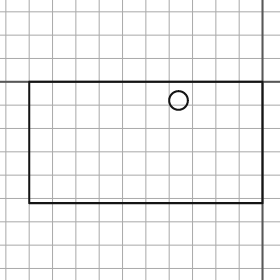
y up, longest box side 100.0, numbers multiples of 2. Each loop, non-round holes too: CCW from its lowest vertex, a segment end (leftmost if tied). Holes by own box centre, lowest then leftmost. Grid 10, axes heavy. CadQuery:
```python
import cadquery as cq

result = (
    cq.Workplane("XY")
    .moveTo(-100.0, -52.0)
    .lineTo(0.0, -52.0)
    .lineTo(0.0, 0.0)
    .lineTo(-100.0, 0.0)
    .close()
    .moveTo(-36.0, -8.0)
    .circle(4.0)
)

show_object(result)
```